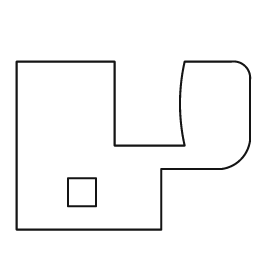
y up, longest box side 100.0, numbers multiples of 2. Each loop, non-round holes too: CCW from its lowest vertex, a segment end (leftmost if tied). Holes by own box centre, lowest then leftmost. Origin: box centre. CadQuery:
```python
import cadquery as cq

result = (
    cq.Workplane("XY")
    .moveTo(-50.0, -36.0)
    .lineTo(12.0, -36.0)
    .lineTo(12.0, -10.0)
    .lineTo(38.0, -10.0)
    .threePointArc((46.0, -6.0), (50.0, 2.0))
    .lineTo(50.0, 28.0)
    .threePointArc((48.0, 34.0), (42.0, 36.0))
    .lineTo(22.0, 36.0)
    .threePointArc((20.0, 18.0), (22.0, 0.0))
    .lineTo(-8.0, 0.0)
    .lineTo(-8.0, 36.0)
    .lineTo(-50.0, 36.0)
    .close()
    .moveTo(-28.0, -26.0)
    .lineTo(-16.0, -26.0)
    .lineTo(-16.0, -14.0)
    .lineTo(-28.0, -14.0)
    .close()
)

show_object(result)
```